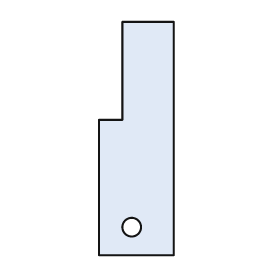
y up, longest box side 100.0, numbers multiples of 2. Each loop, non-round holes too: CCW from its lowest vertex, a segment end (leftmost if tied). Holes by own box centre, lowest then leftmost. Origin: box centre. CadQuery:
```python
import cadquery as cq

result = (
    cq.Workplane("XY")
    .moveTo(-16.0, -50.0)
    .lineTo(16.0, -50.0)
    .lineTo(16.0, 50.0)
    .lineTo(-6.0, 50.0)
    .lineTo(-6.0, 8.0)
    .lineTo(-16.0, 8.0)
    .close()
    .moveTo(-2.0, -38.0)
    .circle(4.0)
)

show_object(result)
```